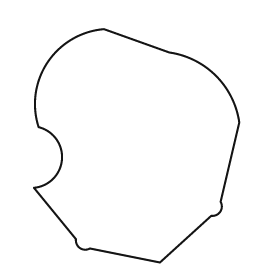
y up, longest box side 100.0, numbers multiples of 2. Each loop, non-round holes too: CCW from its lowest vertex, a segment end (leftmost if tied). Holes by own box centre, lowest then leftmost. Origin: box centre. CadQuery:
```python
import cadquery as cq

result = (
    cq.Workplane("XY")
    .moveTo(10.0, -50.0)
    .lineTo(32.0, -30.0)
    .threePointArc((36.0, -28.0), (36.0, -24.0))
    .lineTo(44.0, 10.0)
    .threePointArc((34.0, 30.0), (14.0, 40.0))
    .lineTo(-14.0, 50.0)
    .threePointArc((-38.0, 36.0), (-42.0, 8.0))
    .threePointArc((-32.0, -6.0), (-44.0, -18.0))
    .lineTo(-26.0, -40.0)
    .threePointArc((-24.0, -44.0), (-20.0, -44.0))
    .close()
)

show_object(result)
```